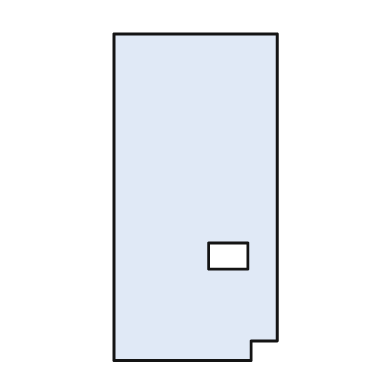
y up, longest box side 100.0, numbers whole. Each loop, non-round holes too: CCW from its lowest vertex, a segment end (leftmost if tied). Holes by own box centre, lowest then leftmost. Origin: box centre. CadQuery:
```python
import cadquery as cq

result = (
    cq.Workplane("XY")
    .moveTo(-25.0, -50.0)
    .lineTo(17.0, -50.0)
    .lineTo(17.0, -44.0)
    .lineTo(25.0, -44.0)
    .lineTo(25.0, 50.0)
    .lineTo(-25.0, 50.0)
    .close()
    .moveTo(4.0, -22.0)
    .lineTo(16.0, -22.0)
    .lineTo(16.0, -14.0)
    .lineTo(4.0, -14.0)
    .close()
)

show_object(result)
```